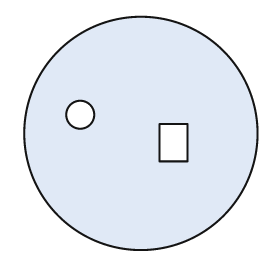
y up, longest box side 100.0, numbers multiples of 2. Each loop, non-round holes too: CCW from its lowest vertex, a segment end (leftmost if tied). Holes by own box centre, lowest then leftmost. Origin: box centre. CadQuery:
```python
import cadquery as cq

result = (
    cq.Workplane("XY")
    .moveTo(0.0, 0.0)
    .circle(50.0)
    .moveTo(8.0, -12.0)
    .lineTo(20.0, -12.0)
    .lineTo(20.0, 4.0)
    .lineTo(8.0, 4.0)
    .close()
    .moveTo(-26.0, 8.0)
    .circle(6.0)
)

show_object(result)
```